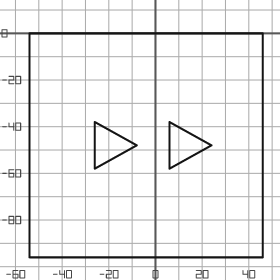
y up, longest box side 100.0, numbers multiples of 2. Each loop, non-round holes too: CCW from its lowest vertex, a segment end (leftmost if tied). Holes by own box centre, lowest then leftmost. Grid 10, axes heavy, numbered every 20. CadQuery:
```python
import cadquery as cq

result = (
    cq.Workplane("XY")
    .moveTo(-54.0, -96.0)
    .lineTo(46.0, -96.0)
    .lineTo(46.0, 0.0)
    .lineTo(-54.0, 0.0)
    .close()
    .moveTo(-26.0, -58.0)
    .lineTo(-8.0, -48.0)
    .lineTo(-26.0, -38.0)
    .close()
    .moveTo(6.0, -58.0)
    .lineTo(24.0, -48.0)
    .lineTo(6.0, -38.0)
    .close()
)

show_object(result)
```